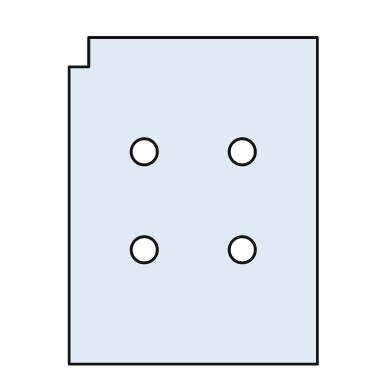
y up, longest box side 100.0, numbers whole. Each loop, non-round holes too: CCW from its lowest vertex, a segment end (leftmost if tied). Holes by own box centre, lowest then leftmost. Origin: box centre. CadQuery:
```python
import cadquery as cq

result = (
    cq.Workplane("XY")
    .moveTo(-38.0, -50.0)
    .lineTo(38.0, -50.0)
    .lineTo(38.0, 50.0)
    .lineTo(-32.0, 50.0)
    .lineTo(-32.0, 41.0)
    .lineTo(-38.0, 41.0)
    .close()
    .moveTo(-15.0, -15.0)
    .circle(4.0)
    .moveTo(15.0, -15.0)
    .circle(4.0)
    .moveTo(-15.0, 15.0)
    .circle(4.0)
    .moveTo(15.0, 15.0)
    .circle(4.0)
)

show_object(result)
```